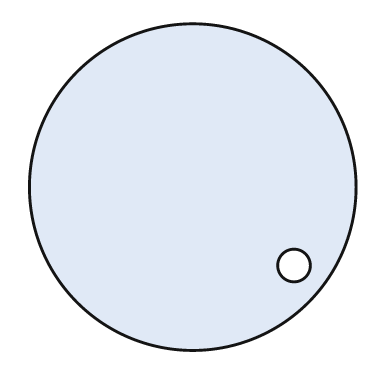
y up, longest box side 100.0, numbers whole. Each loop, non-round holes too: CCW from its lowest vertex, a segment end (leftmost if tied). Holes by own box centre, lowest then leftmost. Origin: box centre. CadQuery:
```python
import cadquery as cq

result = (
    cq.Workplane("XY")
    .moveTo(0.0, 0.0)
    .circle(50.0)
    .moveTo(31.0, -24.0)
    .circle(5.0)
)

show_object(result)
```